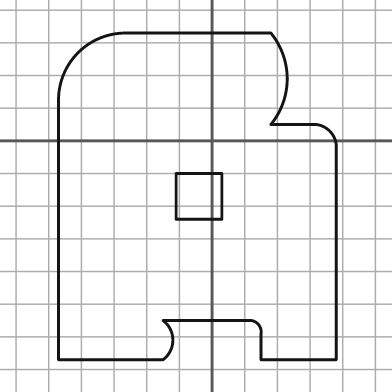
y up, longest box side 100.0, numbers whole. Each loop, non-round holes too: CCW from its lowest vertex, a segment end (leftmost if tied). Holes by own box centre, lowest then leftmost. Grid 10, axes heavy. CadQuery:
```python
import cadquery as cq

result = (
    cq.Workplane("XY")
    .moveTo(-47.0, -67.0)
    .lineTo(-15.0, -67.0)
    .threePointArc((-12.0, -61.0), (-15.0, -55.0))
    .lineTo(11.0, -55.0)
    .threePointArc((14.0, -56.0), (15.0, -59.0))
    .lineTo(15.0, -67.0)
    .lineTo(38.0, -67.0)
    .lineTo(38.0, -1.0)
    .threePointArc((36.0, 3.0), (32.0, 5.0))
    .lineTo(18.0, 5.0)
    .threePointArc((23.0, 19.0), (18.0, 33.0))
    .lineTo(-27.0, 33.0)
    .threePointArc((-41.0, 27.0), (-47.0, 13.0))
    .close()
    .moveTo(-11.0, -24.0)
    .lineTo(3.0, -24.0)
    .lineTo(3.0, -10.0)
    .lineTo(-11.0, -10.0)
    .close()
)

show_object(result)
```